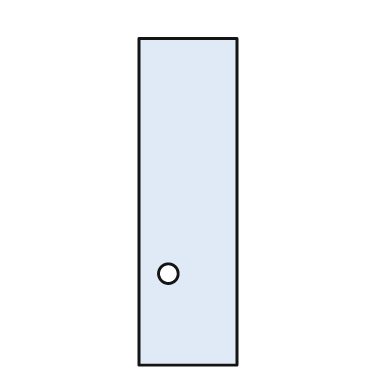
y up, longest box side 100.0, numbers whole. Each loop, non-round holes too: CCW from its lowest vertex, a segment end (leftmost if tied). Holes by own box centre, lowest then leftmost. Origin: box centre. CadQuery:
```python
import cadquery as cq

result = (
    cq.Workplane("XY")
    .moveTo(-15.0, -50.0)
    .lineTo(15.0, -50.0)
    .lineTo(15.0, 50.0)
    .lineTo(-15.0, 50.0)
    .close()
    .moveTo(-6.0, -22.0)
    .circle(3.0)
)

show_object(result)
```